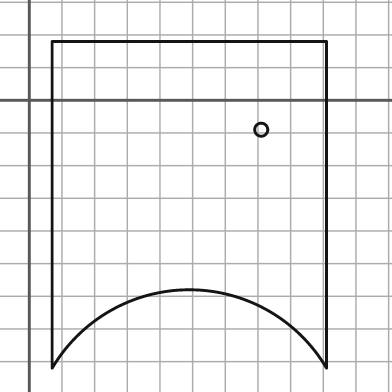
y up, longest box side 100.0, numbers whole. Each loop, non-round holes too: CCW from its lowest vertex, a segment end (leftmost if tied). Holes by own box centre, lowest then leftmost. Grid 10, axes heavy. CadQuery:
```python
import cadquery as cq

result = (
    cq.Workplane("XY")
    .moveTo(7.0, -82.0)
    .threePointArc((49.0, -58.0), (91.0, -82.0))
    .lineTo(91.0, 18.0)
    .lineTo(7.0, 18.0)
    .close()
    .moveTo(71.0, -9.0)
    .circle(2.0)
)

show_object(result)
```